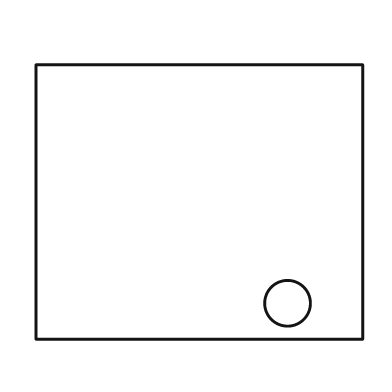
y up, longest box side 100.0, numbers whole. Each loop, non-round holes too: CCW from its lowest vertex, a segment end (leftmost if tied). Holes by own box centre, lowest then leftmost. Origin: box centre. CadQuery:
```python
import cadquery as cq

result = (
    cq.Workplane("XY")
    .moveTo(-50.0, -42.0)
    .lineTo(50.0, -42.0)
    .lineTo(50.0, 42.0)
    .lineTo(-50.0, 42.0)
    .close()
    .moveTo(27.0, -31.0)
    .circle(7.0)
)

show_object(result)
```